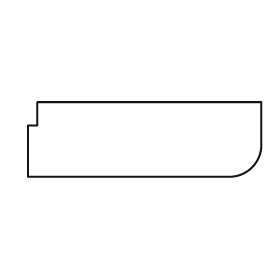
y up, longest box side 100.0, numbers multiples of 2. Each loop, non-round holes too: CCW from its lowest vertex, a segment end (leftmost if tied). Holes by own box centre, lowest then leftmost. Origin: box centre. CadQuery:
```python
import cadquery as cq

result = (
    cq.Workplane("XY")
    .moveTo(-50.0, -16.0)
    .lineTo(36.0, -16.0)
    .threePointArc((46.0, -12.0), (50.0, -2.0))
    .lineTo(50.0, 16.0)
    .lineTo(-46.0, 16.0)
    .lineTo(-46.0, 6.0)
    .lineTo(-50.0, 6.0)
    .close()
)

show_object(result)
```